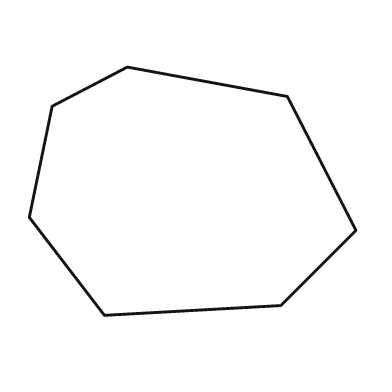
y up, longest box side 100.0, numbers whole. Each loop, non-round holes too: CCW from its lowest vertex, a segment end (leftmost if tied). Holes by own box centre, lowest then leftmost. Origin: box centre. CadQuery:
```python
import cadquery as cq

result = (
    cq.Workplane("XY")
    .moveTo(-27.0, -38.0)
    .lineTo(27.0, -35.0)
    .lineTo(50.0, -12.0)
    .lineTo(29.0, 29.0)
    .lineTo(-20.0, 38.0)
    .lineTo(-43.0, 26.0)
    .lineTo(-50.0, -8.0)
    .close()
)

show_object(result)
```